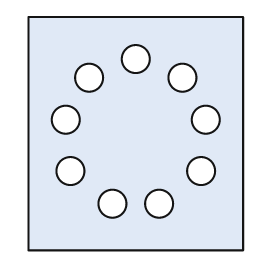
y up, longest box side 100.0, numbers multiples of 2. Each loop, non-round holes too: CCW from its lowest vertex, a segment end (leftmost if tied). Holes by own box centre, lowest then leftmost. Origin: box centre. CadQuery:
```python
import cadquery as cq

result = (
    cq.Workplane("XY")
    .moveTo(-46.0, -50.0)
    .lineTo(46.0, -50.0)
    .lineTo(46.0, 50.0)
    .lineTo(-46.0, 50.0)
    .close()
    .moveTo(-10.0, -30.0)
    .circle(6.0)
    .moveTo(10.0, -30.0)
    .circle(6.0)
    .moveTo(-28.0, -16.0)
    .circle(6.0)
    .moveTo(28.0, -16.0)
    .circle(6.0)
    .moveTo(-30.0, 6.0)
    .circle(6.0)
    .moveTo(30.0, 6.0)
    .circle(6.0)
    .moveTo(-20.0, 24.0)
    .circle(6.0)
    .moveTo(20.0, 24.0)
    .circle(6.0)
    .moveTo(0.0, 32.0)
    .circle(6.0)
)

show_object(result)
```